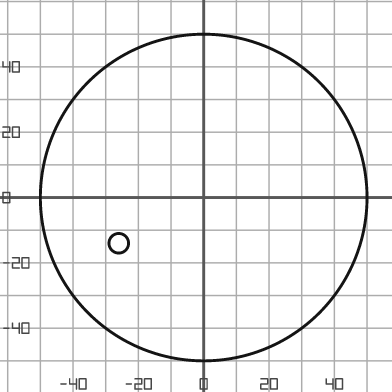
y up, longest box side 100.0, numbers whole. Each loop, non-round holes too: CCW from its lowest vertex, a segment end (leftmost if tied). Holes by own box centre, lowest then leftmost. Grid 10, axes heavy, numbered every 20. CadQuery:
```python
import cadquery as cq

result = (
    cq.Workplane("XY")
    .moveTo(0.0, 0.0)
    .circle(50.0)
    .moveTo(-26.0, -14.0)
    .circle(3.0)
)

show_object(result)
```